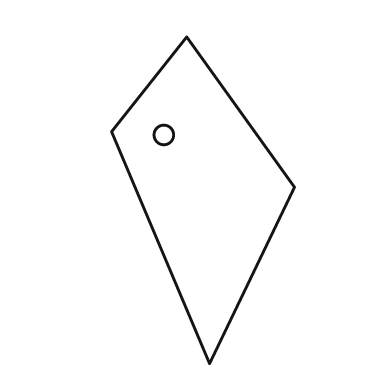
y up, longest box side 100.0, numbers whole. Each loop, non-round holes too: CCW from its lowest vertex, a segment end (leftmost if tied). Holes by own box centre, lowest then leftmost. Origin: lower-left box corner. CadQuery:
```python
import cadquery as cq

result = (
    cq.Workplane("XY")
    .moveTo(30.0, 0.0)
    .lineTo(56.0, 54.0)
    .lineTo(23.0, 100.0)
    .lineTo(0.0, 71.0)
    .close()
    .moveTo(16.0, 70.0)
    .circle(3.0)
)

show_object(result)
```